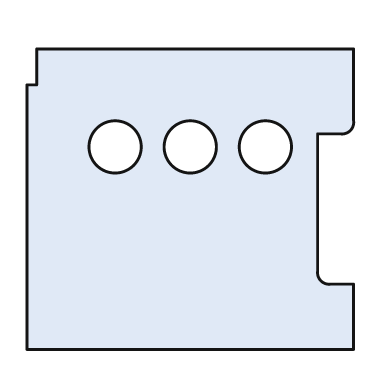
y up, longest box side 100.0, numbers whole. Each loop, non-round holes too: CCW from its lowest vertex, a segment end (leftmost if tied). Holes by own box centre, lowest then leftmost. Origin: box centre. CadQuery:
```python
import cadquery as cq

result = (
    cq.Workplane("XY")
    .moveTo(-50.0, -46.0)
    .lineTo(50.0, -46.0)
    .lineTo(50.0, -26.0)
    .lineTo(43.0, -26.0)
    .threePointArc((40.0, -25.0), (39.0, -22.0))
    .lineTo(39.0, 20.0)
    .lineTo(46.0, 20.0)
    .threePointArc((49.0, 21.0), (50.0, 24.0))
    .lineTo(50.0, 46.0)
    .lineTo(-47.0, 46.0)
    .lineTo(-47.0, 35.0)
    .lineTo(-50.0, 35.0)
    .close()
    .moveTo(-23.0, 16.0)
    .circle(8.0)
    .moveTo(0.0, 16.0)
    .circle(8.0)
    .moveTo(23.0, 16.0)
    .circle(8.0)
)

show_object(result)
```